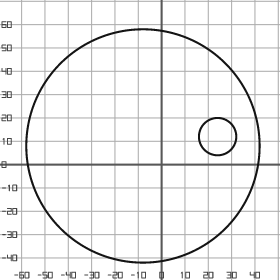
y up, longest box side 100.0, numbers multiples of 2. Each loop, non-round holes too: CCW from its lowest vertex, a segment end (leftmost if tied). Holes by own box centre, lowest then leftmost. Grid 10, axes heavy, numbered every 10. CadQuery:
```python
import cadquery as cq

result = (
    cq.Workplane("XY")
    .moveTo(-8.0, 8.0)
    .circle(50.0)
    .moveTo(24.0, 12.0)
    .circle(8.0)
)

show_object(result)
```